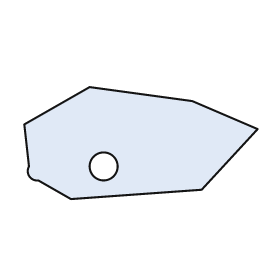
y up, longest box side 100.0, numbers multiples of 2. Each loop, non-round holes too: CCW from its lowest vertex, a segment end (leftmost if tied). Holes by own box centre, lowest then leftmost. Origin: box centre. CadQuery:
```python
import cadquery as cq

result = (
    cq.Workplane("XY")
    .moveTo(-30.0, -24.0)
    .lineTo(26.0, -20.0)
    .lineTo(50.0, 6.0)
    .lineTo(22.0, 18.0)
    .lineTo(-22.0, 24.0)
    .lineTo(-50.0, 8.0)
    .lineTo(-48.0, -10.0)
    .threePointArc((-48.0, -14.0), (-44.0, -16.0))
    .close()
    .moveTo(-16.0, -10.0)
    .circle(6.0)
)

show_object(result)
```